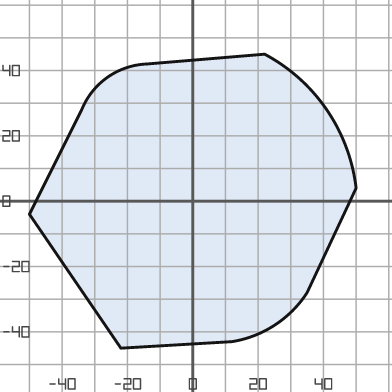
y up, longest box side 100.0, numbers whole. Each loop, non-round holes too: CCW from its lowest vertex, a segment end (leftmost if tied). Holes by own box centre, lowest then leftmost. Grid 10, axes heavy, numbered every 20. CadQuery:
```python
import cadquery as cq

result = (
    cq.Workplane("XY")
    .moveTo(-22.0, -45.0)
    .lineTo(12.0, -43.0)
    .threePointArc((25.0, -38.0), (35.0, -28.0))
    .lineTo(50.0, 4.0)
    .threePointArc((41.0, 28.0), (22.0, 45.0))
    .lineTo(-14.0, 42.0)
    .threePointArc((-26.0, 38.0), (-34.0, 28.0))
    .lineTo(-50.0, -4.0)
    .close()
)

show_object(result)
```